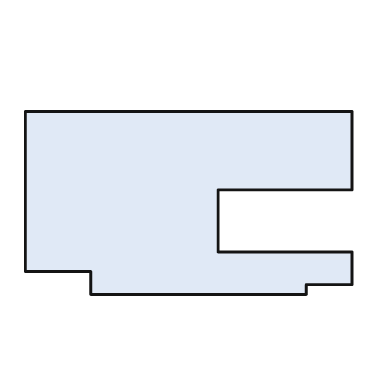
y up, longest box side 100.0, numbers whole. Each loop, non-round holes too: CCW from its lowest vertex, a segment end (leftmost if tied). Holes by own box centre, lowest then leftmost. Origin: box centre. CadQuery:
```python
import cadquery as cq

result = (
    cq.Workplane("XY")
    .moveTo(-30.0, -28.0)
    .lineTo(36.0, -28.0)
    .lineTo(36.0, -25.0)
    .lineTo(50.0, -25.0)
    .lineTo(50.0, -15.0)
    .lineTo(9.0, -15.0)
    .lineTo(9.0, 4.0)
    .lineTo(50.0, 4.0)
    .lineTo(50.0, 28.0)
    .lineTo(-50.0, 28.0)
    .lineTo(-50.0, -21.0)
    .lineTo(-30.0, -21.0)
    .close()
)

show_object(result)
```